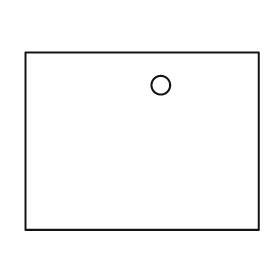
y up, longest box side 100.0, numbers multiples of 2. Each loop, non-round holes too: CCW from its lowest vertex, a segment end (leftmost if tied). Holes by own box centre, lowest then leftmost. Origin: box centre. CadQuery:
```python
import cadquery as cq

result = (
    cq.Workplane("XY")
    .moveTo(-50.0, -38.0)
    .lineTo(50.0, -38.0)
    .lineTo(50.0, 38.0)
    .lineTo(-50.0, 38.0)
    .close()
    .moveTo(8.0, 24.0)
    .circle(4.0)
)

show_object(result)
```